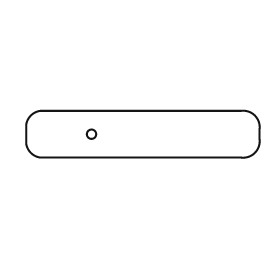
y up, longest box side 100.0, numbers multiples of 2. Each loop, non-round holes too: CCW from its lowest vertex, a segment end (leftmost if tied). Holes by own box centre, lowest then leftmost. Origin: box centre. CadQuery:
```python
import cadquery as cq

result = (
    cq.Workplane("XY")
    .moveTo(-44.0, -10.0)
    .lineTo(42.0, -10.0)
    .threePointArc((48.0, -8.0), (50.0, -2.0))
    .lineTo(50.0, 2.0)
    .threePointArc((48.0, 8.0), (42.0, 10.0))
    .lineTo(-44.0, 10.0)
    .threePointArc((-48.0, 8.0), (-50.0, 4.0))
    .lineTo(-50.0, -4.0)
    .threePointArc((-48.0, -8.0), (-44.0, -10.0))
    .close()
    .moveTo(-22.0, 0.0)
    .circle(2.0)
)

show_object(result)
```